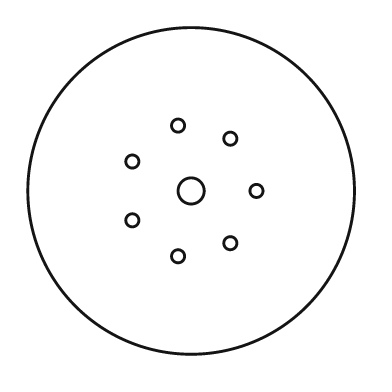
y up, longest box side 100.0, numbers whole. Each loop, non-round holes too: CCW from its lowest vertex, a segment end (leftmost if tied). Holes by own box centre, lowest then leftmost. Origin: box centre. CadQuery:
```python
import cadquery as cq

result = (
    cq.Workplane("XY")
    .moveTo(0.0, 0.0)
    .circle(50.0)
    .moveTo(-4.0, -20.0)
    .circle(2.0)
    .moveTo(12.0, -16.0)
    .circle(2.0)
    .moveTo(-18.0, -9.0)
    .circle(2.0)
    .moveTo(0.0, 0.0)
    .circle(4.0)
    .moveTo(20.0, 0.0)
    .circle(2.0)
    .moveTo(-18.0, 9.0)
    .circle(2.0)
    .moveTo(12.0, 16.0)
    .circle(2.0)
    .moveTo(-4.0, 20.0)
    .circle(2.0)
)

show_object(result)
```